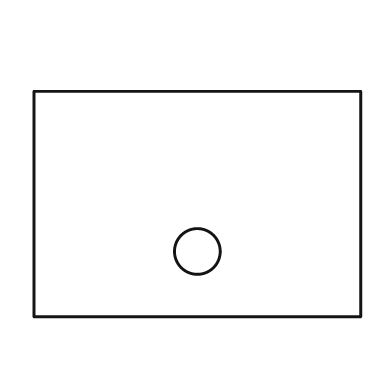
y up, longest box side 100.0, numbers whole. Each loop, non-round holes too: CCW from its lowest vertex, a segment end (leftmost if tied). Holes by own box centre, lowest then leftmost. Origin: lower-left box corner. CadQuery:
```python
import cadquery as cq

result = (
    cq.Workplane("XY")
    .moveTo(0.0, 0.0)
    .lineTo(100.0, 0.0)
    .lineTo(100.0, 69.0)
    .lineTo(0.0, 69.0)
    .close()
    .moveTo(50.0, 20.0)
    .circle(7.0)
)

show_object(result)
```